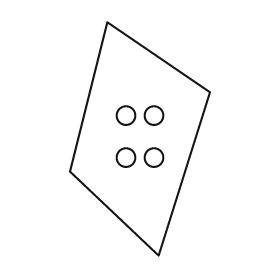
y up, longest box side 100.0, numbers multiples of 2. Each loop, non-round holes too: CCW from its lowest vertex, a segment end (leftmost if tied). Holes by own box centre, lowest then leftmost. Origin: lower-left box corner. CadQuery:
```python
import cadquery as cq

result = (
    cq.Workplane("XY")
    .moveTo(38.0, 0.0)
    .lineTo(60.0, 70.0)
    .lineTo(16.0, 100.0)
    .lineTo(0.0, 36.0)
    .close()
    .moveTo(24.0, 42.0)
    .circle(4.0)
    .moveTo(36.0, 42.0)
    .circle(4.0)
    .moveTo(24.0, 60.0)
    .circle(4.0)
    .moveTo(36.0, 60.0)
    .circle(4.0)
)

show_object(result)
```